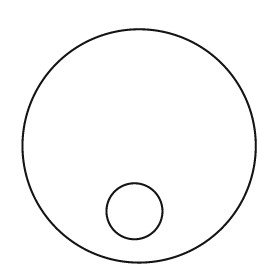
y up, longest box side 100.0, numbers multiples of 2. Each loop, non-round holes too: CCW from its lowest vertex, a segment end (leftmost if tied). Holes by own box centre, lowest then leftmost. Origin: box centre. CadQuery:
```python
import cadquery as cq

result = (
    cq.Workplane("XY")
    .moveTo(0.0, 0.0)
    .circle(50.0)
    .moveTo(-2.0, -28.0)
    .circle(12.0)
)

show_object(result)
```